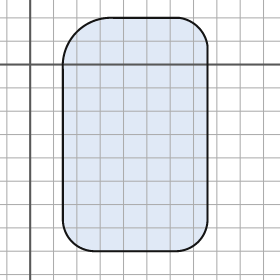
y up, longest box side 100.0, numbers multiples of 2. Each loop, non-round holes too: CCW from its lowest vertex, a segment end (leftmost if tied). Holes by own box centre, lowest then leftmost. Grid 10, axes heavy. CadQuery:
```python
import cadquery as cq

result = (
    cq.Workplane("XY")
    .moveTo(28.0, -80.0)
    .lineTo(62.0, -80.0)
    .threePointArc((72.0, -76.0), (76.0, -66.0))
    .lineTo(76.0, 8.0)
    .threePointArc((72.0, 16.0), (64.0, 20.0))
    .lineTo(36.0, 20.0)
    .threePointArc((20.0, 14.0), (14.0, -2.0))
    .lineTo(14.0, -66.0)
    .threePointArc((18.0, -76.0), (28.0, -80.0))
    .close()
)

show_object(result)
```